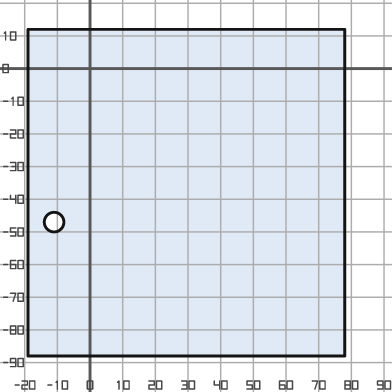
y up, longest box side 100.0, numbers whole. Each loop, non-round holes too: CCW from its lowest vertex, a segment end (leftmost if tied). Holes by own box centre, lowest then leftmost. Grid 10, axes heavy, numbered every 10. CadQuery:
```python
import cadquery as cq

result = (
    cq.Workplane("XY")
    .moveTo(-19.0, -88.0)
    .lineTo(78.0, -88.0)
    .lineTo(78.0, 12.0)
    .lineTo(-19.0, 12.0)
    .close()
    .moveTo(-11.0, -47.0)
    .circle(3.0)
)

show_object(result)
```